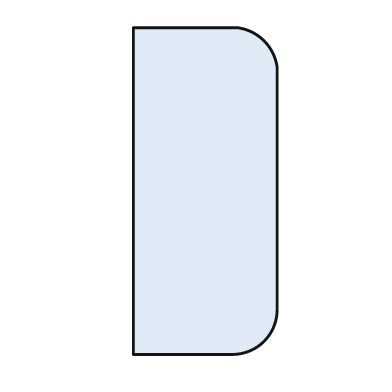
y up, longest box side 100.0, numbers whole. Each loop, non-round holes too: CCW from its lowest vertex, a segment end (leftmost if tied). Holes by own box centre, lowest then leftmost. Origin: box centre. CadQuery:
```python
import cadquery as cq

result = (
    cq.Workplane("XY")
    .moveTo(-22.0, -50.0)
    .lineTo(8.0, -50.0)
    .threePointArc((18.0, -46.0), (22.0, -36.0))
    .lineTo(22.0, 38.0)
    .threePointArc((18.0, 46.0), (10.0, 50.0))
    .lineTo(-22.0, 50.0)
    .close()
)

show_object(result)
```